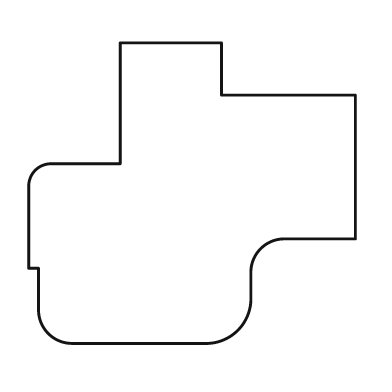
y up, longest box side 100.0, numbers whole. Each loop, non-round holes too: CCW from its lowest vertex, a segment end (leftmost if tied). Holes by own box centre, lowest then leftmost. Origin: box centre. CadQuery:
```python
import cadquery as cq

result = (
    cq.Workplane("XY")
    .moveTo(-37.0, -46.0)
    .lineTo(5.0, -46.0)
    .threePointArc((14.0, -42.0), (18.0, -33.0))
    .lineTo(18.0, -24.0)
    .threePointArc((21.0, -17.0), (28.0, -14.0))
    .lineTo(50.0, -14.0)
    .lineTo(50.0, 30.0)
    .lineTo(9.0, 30.0)
    .lineTo(9.0, 46.0)
    .lineTo(-22.0, 46.0)
    .lineTo(-22.0, 9.0)
    .lineTo(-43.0, 9.0)
    .threePointArc((-48.0, 7.0), (-50.0, 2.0))
    .lineTo(-50.0, -23.0)
    .lineTo(-47.0, -23.0)
    .lineTo(-47.0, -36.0)
    .threePointArc((-44.0, -43.0), (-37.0, -46.0))
    .close()
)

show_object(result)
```